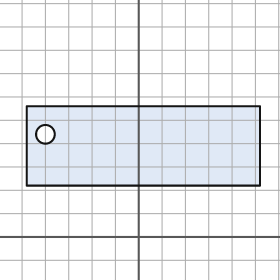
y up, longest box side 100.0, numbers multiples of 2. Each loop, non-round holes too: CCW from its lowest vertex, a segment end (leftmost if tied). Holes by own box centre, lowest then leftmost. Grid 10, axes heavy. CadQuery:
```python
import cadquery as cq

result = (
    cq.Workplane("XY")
    .moveTo(-48.0, 22.0)
    .lineTo(52.0, 22.0)
    .lineTo(52.0, 56.0)
    .lineTo(-48.0, 56.0)
    .close()
    .moveTo(-40.0, 44.0)
    .circle(4.0)
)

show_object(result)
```